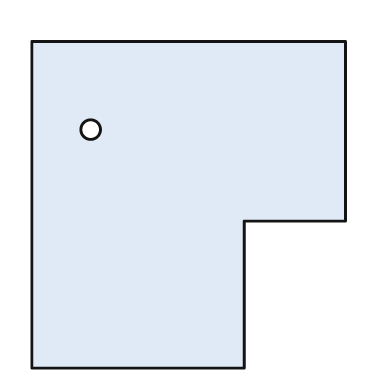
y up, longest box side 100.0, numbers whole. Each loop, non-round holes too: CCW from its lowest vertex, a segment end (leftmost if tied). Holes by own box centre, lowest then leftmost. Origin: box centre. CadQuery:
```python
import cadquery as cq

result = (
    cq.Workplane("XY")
    .moveTo(-48.0, -50.0)
    .lineTo(17.0, -50.0)
    .lineTo(17.0, -5.0)
    .lineTo(48.0, -5.0)
    .lineTo(48.0, 50.0)
    .lineTo(-48.0, 50.0)
    .close()
    .moveTo(-30.0, 23.0)
    .circle(3.0)
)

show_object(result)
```